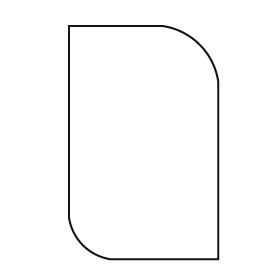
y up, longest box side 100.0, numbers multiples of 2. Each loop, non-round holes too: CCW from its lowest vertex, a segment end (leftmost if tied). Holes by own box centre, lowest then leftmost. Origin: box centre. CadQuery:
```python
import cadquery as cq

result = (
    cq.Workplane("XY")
    .moveTo(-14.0, -50.0)
    .lineTo(32.0, -50.0)
    .lineTo(32.0, 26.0)
    .threePointArc((24.0, 42.0), (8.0, 50.0))
    .lineTo(-32.0, 50.0)
    .lineTo(-32.0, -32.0)
    .threePointArc((-26.0, -44.0), (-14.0, -50.0))
    .close()
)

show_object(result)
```